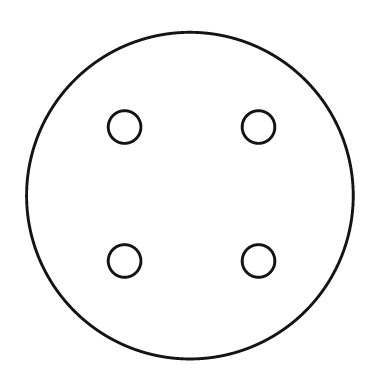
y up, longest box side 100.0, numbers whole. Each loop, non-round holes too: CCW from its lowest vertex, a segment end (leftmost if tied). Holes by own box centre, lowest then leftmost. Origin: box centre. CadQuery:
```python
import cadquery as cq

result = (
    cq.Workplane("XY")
    .moveTo(0.0, 0.0)
    .circle(50.0)
    .moveTo(-20.0, -20.0)
    .circle(5.0)
    .moveTo(21.0, -20.0)
    .circle(5.0)
    .moveTo(-20.0, 21.0)
    .circle(5.0)
    .moveTo(21.0, 21.0)
    .circle(5.0)
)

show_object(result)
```